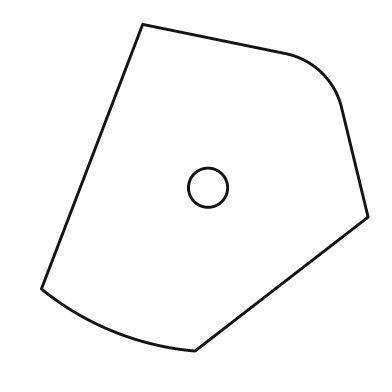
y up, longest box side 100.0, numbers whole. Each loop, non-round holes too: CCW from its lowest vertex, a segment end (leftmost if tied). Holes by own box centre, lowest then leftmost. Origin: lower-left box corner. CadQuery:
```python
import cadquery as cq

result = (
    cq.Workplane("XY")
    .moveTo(47.0, 0.0)
    .lineTo(100.0, 41.0)
    .lineTo(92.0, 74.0)
    .threePointArc((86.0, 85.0), (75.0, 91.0))
    .lineTo(31.0, 100.0)
    .lineTo(0.0, 19.0)
    .threePointArc((22.0, 6.0), (47.0, 0.0))
    .close()
    .moveTo(51.0, 50.0)
    .circle(6.0)
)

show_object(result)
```